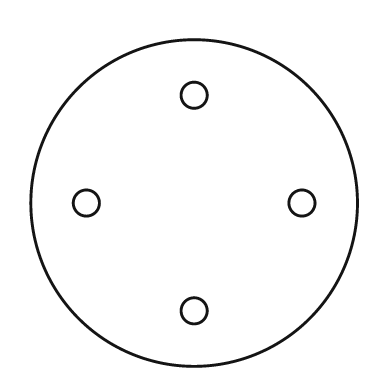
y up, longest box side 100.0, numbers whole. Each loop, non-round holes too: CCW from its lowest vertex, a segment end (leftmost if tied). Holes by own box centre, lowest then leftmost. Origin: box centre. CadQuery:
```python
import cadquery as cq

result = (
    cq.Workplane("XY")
    .moveTo(0.0, 0.0)
    .circle(50.0)
    .moveTo(0.0, -33.0)
    .circle(4.0)
    .moveTo(-33.0, 0.0)
    .circle(4.0)
    .moveTo(33.0, 0.0)
    .circle(4.0)
    .moveTo(0.0, 33.0)
    .circle(4.0)
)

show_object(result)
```